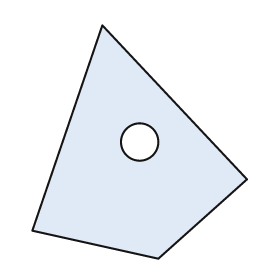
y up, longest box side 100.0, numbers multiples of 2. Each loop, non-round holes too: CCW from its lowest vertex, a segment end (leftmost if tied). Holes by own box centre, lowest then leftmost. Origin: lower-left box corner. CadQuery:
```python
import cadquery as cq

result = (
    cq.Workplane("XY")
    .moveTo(54.0, 0.0)
    .lineTo(92.0, 34.0)
    .lineTo(30.0, 100.0)
    .lineTo(0.0, 12.0)
    .close()
    .moveTo(46.0, 50.0)
    .circle(8.0)
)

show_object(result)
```